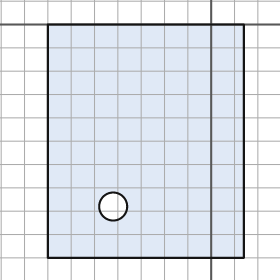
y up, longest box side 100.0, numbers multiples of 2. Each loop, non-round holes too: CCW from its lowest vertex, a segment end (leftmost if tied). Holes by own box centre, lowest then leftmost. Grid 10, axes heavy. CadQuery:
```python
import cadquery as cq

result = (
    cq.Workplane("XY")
    .moveTo(-70.0, -100.0)
    .lineTo(14.0, -100.0)
    .lineTo(14.0, 0.0)
    .lineTo(-70.0, 0.0)
    .close()
    .moveTo(-42.0, -78.0)
    .circle(6.0)
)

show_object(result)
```